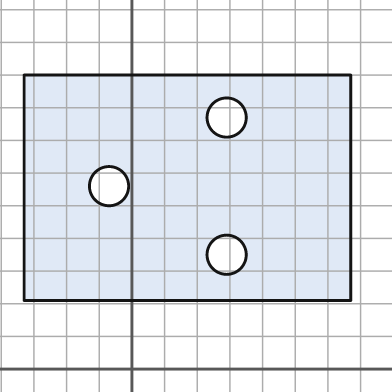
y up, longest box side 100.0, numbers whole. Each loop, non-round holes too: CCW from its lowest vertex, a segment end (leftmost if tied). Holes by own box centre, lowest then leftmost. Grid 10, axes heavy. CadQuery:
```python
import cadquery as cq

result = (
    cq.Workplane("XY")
    .moveTo(-33.0, 21.0)
    .lineTo(67.0, 21.0)
    .lineTo(67.0, 90.0)
    .lineTo(-33.0, 90.0)
    .close()
    .moveTo(29.0, 35.0)
    .circle(6.0)
    .moveTo(-7.0, 56.0)
    .circle(6.0)
    .moveTo(29.0, 77.0)
    .circle(6.0)
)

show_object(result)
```